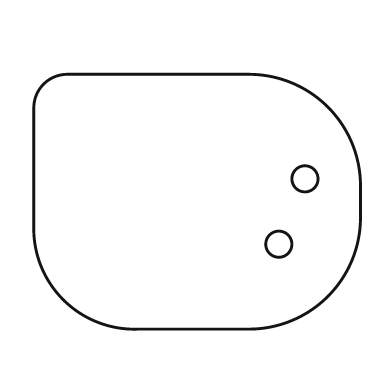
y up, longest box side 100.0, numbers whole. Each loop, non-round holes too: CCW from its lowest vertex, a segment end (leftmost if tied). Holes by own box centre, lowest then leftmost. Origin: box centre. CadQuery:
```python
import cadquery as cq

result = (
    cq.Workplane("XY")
    .moveTo(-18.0, -39.0)
    .lineTo(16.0, -39.0)
    .threePointArc((40.0, -29.0), (50.0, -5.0))
    .lineTo(50.0, 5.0)
    .threePointArc((40.0, 29.0), (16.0, 39.0))
    .lineTo(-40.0, 39.0)
    .threePointArc((-47.0, 36.0), (-50.0, 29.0))
    .lineTo(-50.0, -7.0)
    .threePointArc((-41.0, -30.0), (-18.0, -39.0))
    .close()
    .moveTo(25.0, -13.0)
    .circle(4.0)
    .moveTo(33.0, 7.0)
    .circle(4.0)
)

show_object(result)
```